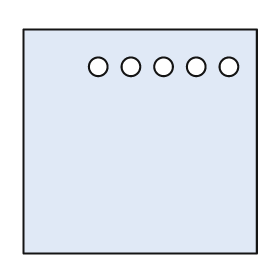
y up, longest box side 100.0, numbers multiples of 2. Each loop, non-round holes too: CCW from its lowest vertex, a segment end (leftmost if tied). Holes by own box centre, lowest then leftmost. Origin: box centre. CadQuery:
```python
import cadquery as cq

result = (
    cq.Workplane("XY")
    .moveTo(-50.0, -48.0)
    .lineTo(50.0, -48.0)
    .lineTo(50.0, 48.0)
    .lineTo(-50.0, 48.0)
    .close()
    .moveTo(-18.0, 32.0)
    .circle(4.0)
    .moveTo(-4.0, 32.0)
    .circle(4.0)
    .moveTo(10.0, 32.0)
    .circle(4.0)
    .moveTo(24.0, 32.0)
    .circle(4.0)
    .moveTo(38.0, 32.0)
    .circle(4.0)
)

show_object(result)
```